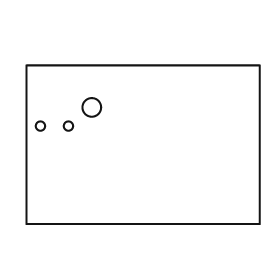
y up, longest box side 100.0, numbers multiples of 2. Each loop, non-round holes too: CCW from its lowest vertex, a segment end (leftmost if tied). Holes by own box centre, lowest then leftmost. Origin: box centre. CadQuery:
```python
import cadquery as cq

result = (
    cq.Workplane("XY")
    .moveTo(-50.0, -34.0)
    .lineTo(50.0, -34.0)
    .lineTo(50.0, 34.0)
    .lineTo(-50.0, 34.0)
    .close()
    .moveTo(-44.0, 8.0)
    .circle(2.0)
    .moveTo(-32.0, 8.0)
    .circle(2.0)
    .moveTo(-22.0, 16.0)
    .circle(4.0)
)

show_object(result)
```